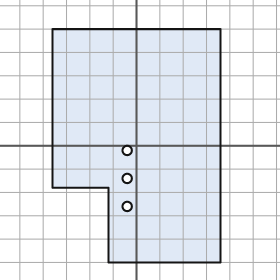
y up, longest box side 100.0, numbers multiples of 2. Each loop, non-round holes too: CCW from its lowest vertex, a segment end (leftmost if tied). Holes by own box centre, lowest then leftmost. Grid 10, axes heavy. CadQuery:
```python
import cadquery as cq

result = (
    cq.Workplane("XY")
    .moveTo(-12.0, -50.0)
    .lineTo(36.0, -50.0)
    .lineTo(36.0, 50.0)
    .lineTo(-36.0, 50.0)
    .lineTo(-36.0, -18.0)
    .lineTo(-12.0, -18.0)
    .close()
    .moveTo(-4.0, -26.0)
    .circle(2.0)
    .moveTo(-4.0, -14.0)
    .circle(2.0)
    .moveTo(-4.0, -2.0)
    .circle(2.0)
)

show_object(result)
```